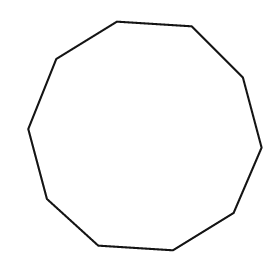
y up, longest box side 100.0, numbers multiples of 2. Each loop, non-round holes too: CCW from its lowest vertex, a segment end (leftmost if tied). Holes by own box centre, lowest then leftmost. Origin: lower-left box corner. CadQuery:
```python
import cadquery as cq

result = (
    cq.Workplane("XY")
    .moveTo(62.0, 0.0)
    .lineTo(88.0, 16.0)
    .lineTo(100.0, 44.0)
    .lineTo(92.0, 74.0)
    .lineTo(70.0, 96.0)
    .lineTo(38.0, 98.0)
    .lineTo(12.0, 82.0)
    .lineTo(0.0, 52.0)
    .lineTo(8.0, 22.0)
    .lineTo(30.0, 2.0)
    .close()
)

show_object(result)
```